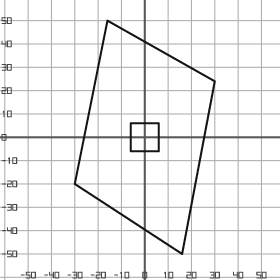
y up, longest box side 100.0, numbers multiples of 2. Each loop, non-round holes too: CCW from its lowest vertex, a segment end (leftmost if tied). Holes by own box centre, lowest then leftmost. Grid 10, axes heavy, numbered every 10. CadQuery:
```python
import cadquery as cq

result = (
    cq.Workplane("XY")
    .moveTo(16.0, -50.0)
    .lineTo(30.0, 24.0)
    .lineTo(-16.0, 50.0)
    .lineTo(-30.0, -20.0)
    .close()
    .moveTo(-6.0, -6.0)
    .lineTo(6.0, -6.0)
    .lineTo(6.0, 6.0)
    .lineTo(-6.0, 6.0)
    .close()
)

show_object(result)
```